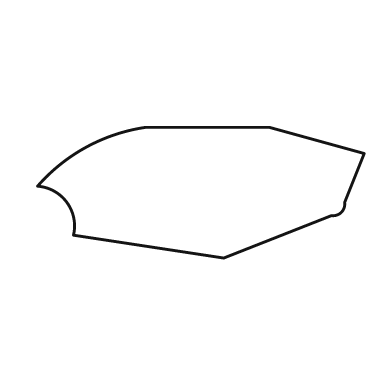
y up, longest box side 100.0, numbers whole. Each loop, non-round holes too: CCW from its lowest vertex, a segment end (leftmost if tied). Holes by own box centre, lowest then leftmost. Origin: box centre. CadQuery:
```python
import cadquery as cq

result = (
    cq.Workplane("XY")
    .moveTo(7.0, -20.0)
    .lineTo(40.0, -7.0)
    .threePointArc((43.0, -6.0), (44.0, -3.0))
    .lineTo(50.0, 12.0)
    .lineTo(21.0, 20.0)
    .lineTo(-17.0, 20.0)
    .threePointArc((-35.0, 14.0), (-50.0, 2.0))
    .threePointArc((-41.0, -3.0), (-39.0, -13.0))
    .close()
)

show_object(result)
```